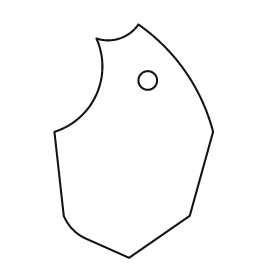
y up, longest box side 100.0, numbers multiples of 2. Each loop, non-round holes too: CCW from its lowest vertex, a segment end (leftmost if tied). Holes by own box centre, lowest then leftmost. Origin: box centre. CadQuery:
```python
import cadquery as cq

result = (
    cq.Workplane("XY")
    .moveTo(-2.0, -50.0)
    .lineTo(24.0, -32.0)
    .lineTo(34.0, 4.0)
    .threePointArc((22.0, 30.0), (2.0, 50.0))
    .threePointArc((-6.0, 44.0), (-16.0, 44.0))
    .threePointArc((-16.0, 20.0), (-34.0, 4.0))
    .lineTo(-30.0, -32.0)
    .threePointArc((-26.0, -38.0), (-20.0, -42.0))
    .close()
    .moveTo(6.0, 26.0)
    .circle(4.0)
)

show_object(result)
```